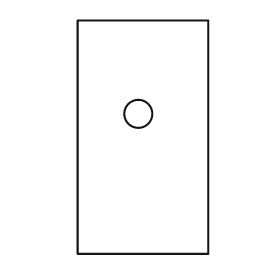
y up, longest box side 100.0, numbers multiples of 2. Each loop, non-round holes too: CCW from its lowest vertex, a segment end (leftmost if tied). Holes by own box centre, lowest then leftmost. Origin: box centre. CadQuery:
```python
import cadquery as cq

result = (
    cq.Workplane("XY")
    .moveTo(-28.0, -50.0)
    .lineTo(28.0, -50.0)
    .lineTo(28.0, 50.0)
    .lineTo(-28.0, 50.0)
    .close()
    .moveTo(-2.0, 10.0)
    .circle(6.0)
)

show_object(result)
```